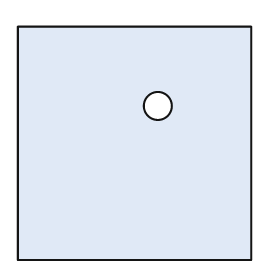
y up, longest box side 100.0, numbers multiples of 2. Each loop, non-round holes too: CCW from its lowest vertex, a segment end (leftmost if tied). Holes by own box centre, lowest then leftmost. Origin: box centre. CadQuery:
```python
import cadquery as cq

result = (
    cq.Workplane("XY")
    .moveTo(-50.0, -50.0)
    .lineTo(50.0, -50.0)
    .lineTo(50.0, 50.0)
    .lineTo(-50.0, 50.0)
    .close()
    .moveTo(10.0, 16.0)
    .circle(6.0)
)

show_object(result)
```